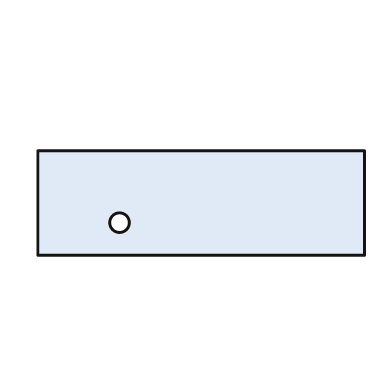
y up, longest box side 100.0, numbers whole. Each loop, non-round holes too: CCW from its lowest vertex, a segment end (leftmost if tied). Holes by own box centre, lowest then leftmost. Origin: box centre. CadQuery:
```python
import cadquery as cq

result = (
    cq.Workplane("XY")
    .moveTo(-50.0, -16.0)
    .lineTo(50.0, -16.0)
    .lineTo(50.0, 16.0)
    .lineTo(-50.0, 16.0)
    .close()
    .moveTo(-25.0, -6.0)
    .circle(3.0)
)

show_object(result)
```